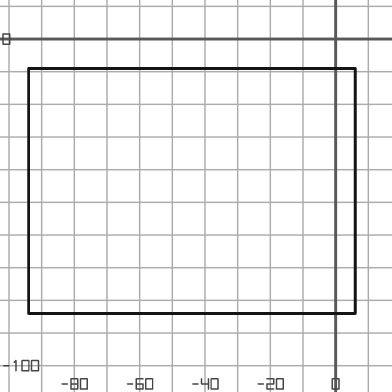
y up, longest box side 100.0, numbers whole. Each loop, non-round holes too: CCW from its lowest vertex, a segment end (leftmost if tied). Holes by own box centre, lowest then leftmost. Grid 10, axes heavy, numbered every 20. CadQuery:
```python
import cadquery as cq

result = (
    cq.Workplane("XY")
    .moveTo(-94.0, -84.0)
    .lineTo(6.0, -84.0)
    .lineTo(6.0, -9.0)
    .lineTo(-94.0, -9.0)
    .close()
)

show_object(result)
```